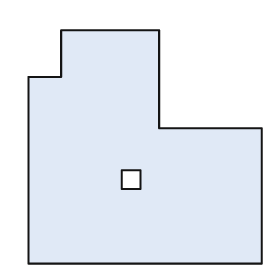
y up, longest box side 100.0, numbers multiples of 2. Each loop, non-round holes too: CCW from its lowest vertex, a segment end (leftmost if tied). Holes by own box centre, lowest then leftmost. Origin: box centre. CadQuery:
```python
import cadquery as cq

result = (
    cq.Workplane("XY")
    .moveTo(-50.0, -50.0)
    .lineTo(50.0, -50.0)
    .lineTo(50.0, 8.0)
    .lineTo(6.0, 8.0)
    .lineTo(6.0, 50.0)
    .lineTo(-36.0, 50.0)
    .lineTo(-36.0, 30.0)
    .lineTo(-50.0, 30.0)
    .close()
    .moveTo(-10.0, -18.0)
    .lineTo(-2.0, -18.0)
    .lineTo(-2.0, -10.0)
    .lineTo(-10.0, -10.0)
    .close()
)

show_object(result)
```